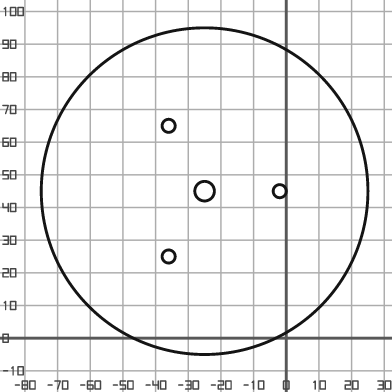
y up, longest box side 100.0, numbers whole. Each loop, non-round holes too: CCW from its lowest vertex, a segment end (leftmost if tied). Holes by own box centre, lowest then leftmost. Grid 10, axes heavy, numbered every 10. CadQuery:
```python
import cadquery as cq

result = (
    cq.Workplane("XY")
    .moveTo(-25.0, 45.0)
    .circle(50.0)
    .moveTo(-36.0, 25.0)
    .circle(2.0)
    .moveTo(-25.0, 45.0)
    .circle(3.0)
    .moveTo(-2.0, 45.0)
    .circle(2.0)
    .moveTo(-36.0, 65.0)
    .circle(2.0)
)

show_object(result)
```